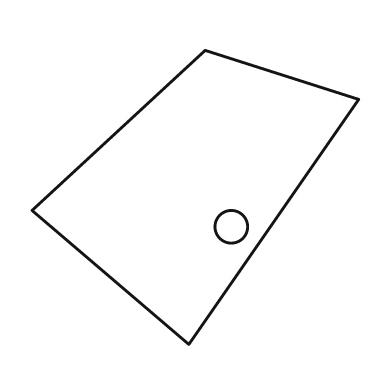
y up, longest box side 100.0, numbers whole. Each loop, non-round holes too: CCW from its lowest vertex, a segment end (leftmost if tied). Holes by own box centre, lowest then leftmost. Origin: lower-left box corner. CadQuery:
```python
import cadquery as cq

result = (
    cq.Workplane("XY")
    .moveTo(48.0, 0.0)
    .lineTo(100.0, 75.0)
    .lineTo(53.0, 90.0)
    .lineTo(0.0, 41.0)
    .close()
    .moveTo(61.0, 36.0)
    .circle(5.0)
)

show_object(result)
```